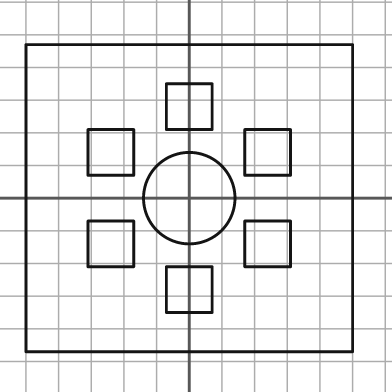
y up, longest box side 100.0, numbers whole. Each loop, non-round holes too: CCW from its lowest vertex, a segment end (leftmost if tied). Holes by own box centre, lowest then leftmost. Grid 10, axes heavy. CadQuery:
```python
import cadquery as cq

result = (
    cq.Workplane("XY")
    .moveTo(-50.0, -47.0)
    .lineTo(50.0, -47.0)
    .lineTo(50.0, 47.0)
    .lineTo(-50.0, 47.0)
    .close()
    .moveTo(-7.0, -35.0)
    .lineTo(7.0, -35.0)
    .lineTo(7.0, -21.0)
    .lineTo(-7.0, -21.0)
    .close()
    .moveTo(-31.0, -21.0)
    .lineTo(-17.0, -21.0)
    .lineTo(-17.0, -7.0)
    .lineTo(-31.0, -7.0)
    .close()
    .moveTo(17.0, -21.0)
    .lineTo(31.0, -21.0)
    .lineTo(31.0, -7.0)
    .lineTo(17.0, -7.0)
    .close()
    .moveTo(0.0, 0.0)
    .circle(14.0)
    .moveTo(-31.0, 7.0)
    .lineTo(-17.0, 7.0)
    .lineTo(-17.0, 21.0)
    .lineTo(-31.0, 21.0)
    .close()
    .moveTo(17.0, 7.0)
    .lineTo(31.0, 7.0)
    .lineTo(31.0, 21.0)
    .lineTo(17.0, 21.0)
    .close()
    .moveTo(-7.0, 21.0)
    .lineTo(7.0, 21.0)
    .lineTo(7.0, 35.0)
    .lineTo(-7.0, 35.0)
    .close()
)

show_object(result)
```